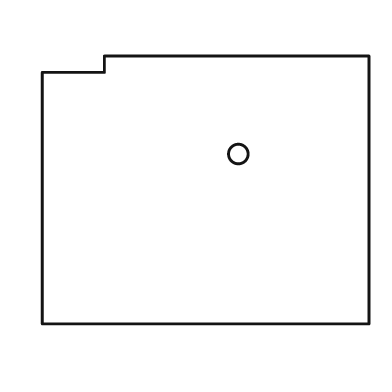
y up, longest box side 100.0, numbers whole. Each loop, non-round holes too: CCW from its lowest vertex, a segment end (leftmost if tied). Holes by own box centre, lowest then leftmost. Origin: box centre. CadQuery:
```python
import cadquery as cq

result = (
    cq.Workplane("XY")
    .moveTo(-50.0, -41.0)
    .lineTo(50.0, -41.0)
    .lineTo(50.0, 41.0)
    .lineTo(-31.0, 41.0)
    .lineTo(-31.0, 36.0)
    .lineTo(-50.0, 36.0)
    .close()
    .moveTo(10.0, 11.0)
    .circle(3.0)
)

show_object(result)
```